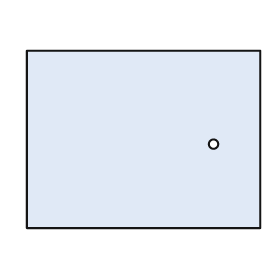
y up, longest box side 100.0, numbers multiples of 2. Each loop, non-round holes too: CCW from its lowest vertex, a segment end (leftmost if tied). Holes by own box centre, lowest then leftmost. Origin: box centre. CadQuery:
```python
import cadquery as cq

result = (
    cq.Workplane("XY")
    .moveTo(-50.0, -38.0)
    .lineTo(50.0, -38.0)
    .lineTo(50.0, 38.0)
    .lineTo(-50.0, 38.0)
    .close()
    .moveTo(30.0, -2.0)
    .circle(2.0)
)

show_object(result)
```